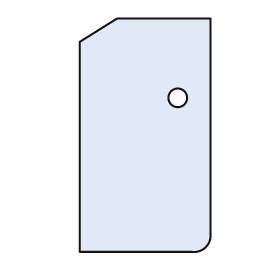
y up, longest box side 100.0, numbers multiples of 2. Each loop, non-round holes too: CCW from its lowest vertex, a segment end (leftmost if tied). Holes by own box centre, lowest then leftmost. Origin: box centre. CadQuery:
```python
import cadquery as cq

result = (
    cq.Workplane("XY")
    .moveTo(-28.0, -50.0)
    .lineTo(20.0, -50.0)
    .threePointArc((26.0, -48.0), (28.0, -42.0))
    .lineTo(28.0, 50.0)
    .lineTo(-12.0, 50.0)
    .lineTo(-28.0, 40.0)
    .close()
    .moveTo(14.0, 16.0)
    .circle(4.0)
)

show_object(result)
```